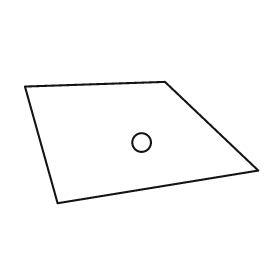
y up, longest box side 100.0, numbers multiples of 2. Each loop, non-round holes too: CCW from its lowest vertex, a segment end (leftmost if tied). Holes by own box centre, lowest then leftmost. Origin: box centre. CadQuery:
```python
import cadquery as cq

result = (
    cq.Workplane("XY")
    .moveTo(-36.0, -26.0)
    .lineTo(50.0, -12.0)
    .lineTo(10.0, 26.0)
    .lineTo(-50.0, 24.0)
    .close()
    .moveTo(0.0, 0.0)
    .circle(4.0)
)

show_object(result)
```